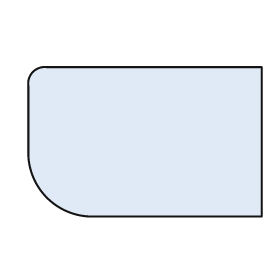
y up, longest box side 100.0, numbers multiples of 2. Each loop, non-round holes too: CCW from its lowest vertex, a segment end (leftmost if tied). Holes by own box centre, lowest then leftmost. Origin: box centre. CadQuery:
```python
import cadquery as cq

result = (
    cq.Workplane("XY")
    .moveTo(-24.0, -32.0)
    .lineTo(50.0, -32.0)
    .lineTo(50.0, 32.0)
    .lineTo(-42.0, 32.0)
    .threePointArc((-48.0, 30.0), (-50.0, 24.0))
    .lineTo(-50.0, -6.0)
    .threePointArc((-42.0, -24.0), (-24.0, -32.0))
    .close()
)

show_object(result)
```